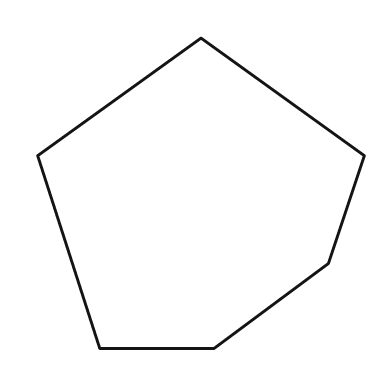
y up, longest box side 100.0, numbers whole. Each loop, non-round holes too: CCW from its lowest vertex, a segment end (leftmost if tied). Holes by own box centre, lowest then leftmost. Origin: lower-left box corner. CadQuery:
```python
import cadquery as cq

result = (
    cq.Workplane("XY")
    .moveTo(19.0, 0.0)
    .lineTo(54.0, 0.0)
    .lineTo(89.0, 26.0)
    .lineTo(100.0, 59.0)
    .lineTo(50.0, 95.0)
    .lineTo(0.0, 59.0)
    .close()
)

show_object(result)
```